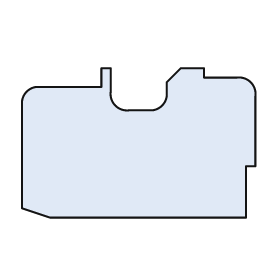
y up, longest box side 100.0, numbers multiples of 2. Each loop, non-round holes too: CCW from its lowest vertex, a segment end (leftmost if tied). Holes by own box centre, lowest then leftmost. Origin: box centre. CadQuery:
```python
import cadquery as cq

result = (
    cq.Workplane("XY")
    .moveTo(-38.0, -32.0)
    .lineTo(46.0, -32.0)
    .lineTo(46.0, -10.0)
    .lineTo(50.0, -10.0)
    .lineTo(50.0, 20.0)
    .threePointArc((48.0, 26.0), (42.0, 28.0))
    .lineTo(28.0, 28.0)
    .lineTo(28.0, 32.0)
    .lineTo(18.0, 32.0)
    .lineTo(12.0, 26.0)
    .lineTo(12.0, 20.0)
    .threePointArc((10.0, 16.0), (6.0, 14.0))
    .lineTo(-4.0, 14.0)
    .threePointArc((-10.0, 16.0), (-12.0, 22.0))
    .lineTo(-12.0, 32.0)
    .lineTo(-16.0, 32.0)
    .lineTo(-16.0, 24.0)
    .lineTo(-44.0, 24.0)
    .threePointArc((-48.0, 22.0), (-50.0, 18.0))
    .lineTo(-50.0, -28.0)
    .close()
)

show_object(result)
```